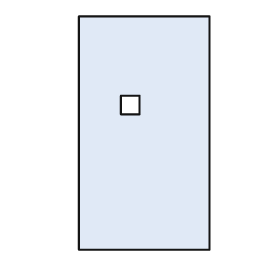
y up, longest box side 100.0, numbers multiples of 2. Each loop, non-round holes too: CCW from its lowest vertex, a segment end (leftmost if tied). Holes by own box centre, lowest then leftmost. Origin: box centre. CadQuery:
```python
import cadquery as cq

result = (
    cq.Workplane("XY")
    .moveTo(-28.0, -50.0)
    .lineTo(28.0, -50.0)
    .lineTo(28.0, 50.0)
    .lineTo(-28.0, 50.0)
    .close()
    .moveTo(-10.0, 8.0)
    .lineTo(-2.0, 8.0)
    .lineTo(-2.0, 16.0)
    .lineTo(-10.0, 16.0)
    .close()
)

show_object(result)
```